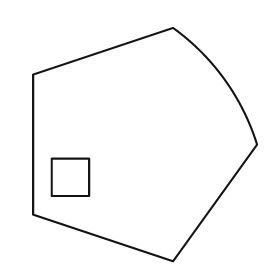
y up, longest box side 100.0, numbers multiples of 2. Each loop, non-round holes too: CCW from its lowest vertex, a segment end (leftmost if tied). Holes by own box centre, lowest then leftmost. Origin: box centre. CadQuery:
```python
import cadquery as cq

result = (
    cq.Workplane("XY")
    .moveTo(12.0, -50.0)
    .lineTo(48.0, 0.0)
    .threePointArc((34.0, 28.0), (12.0, 50.0))
    .lineTo(-48.0, 30.0)
    .lineTo(-48.0, -30.0)
    .close()
    .moveTo(-40.0, -22.0)
    .lineTo(-24.0, -22.0)
    .lineTo(-24.0, -6.0)
    .lineTo(-40.0, -6.0)
    .close()
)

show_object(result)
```